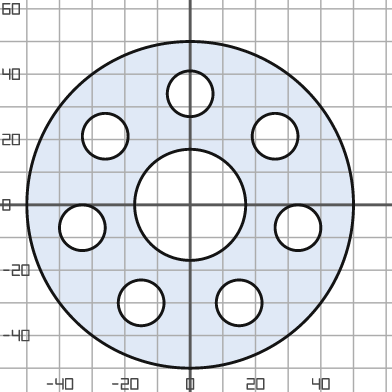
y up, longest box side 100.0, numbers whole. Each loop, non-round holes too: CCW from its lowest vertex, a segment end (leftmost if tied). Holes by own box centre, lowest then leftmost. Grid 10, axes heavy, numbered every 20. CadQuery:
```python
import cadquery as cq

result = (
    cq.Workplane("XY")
    .moveTo(0.0, 0.0)
    .circle(50.0)
    .moveTo(-15.0, -30.0)
    .circle(7.0)
    .moveTo(15.0, -30.0)
    .circle(7.0)
    .moveTo(-33.0, -7.0)
    .circle(7.0)
    .moveTo(33.0, -7.0)
    .circle(7.0)
    .moveTo(0.0, 0.0)
    .circle(17.0)
    .moveTo(-26.0, 21.0)
    .circle(7.0)
    .moveTo(26.0, 21.0)
    .circle(7.0)
    .moveTo(0.0, 34.0)
    .circle(7.0)
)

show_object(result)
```